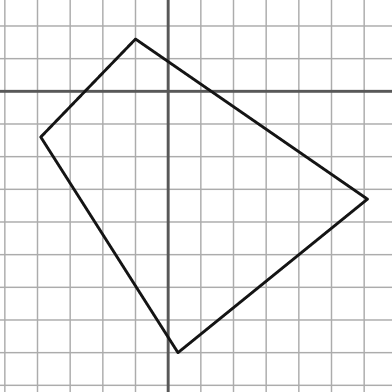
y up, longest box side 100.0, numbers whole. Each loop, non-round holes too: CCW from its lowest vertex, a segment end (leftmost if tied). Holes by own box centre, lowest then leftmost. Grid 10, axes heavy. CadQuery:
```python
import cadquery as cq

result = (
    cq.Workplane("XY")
    .moveTo(3.0, -80.0)
    .lineTo(61.0, -33.0)
    .lineTo(-10.0, 16.0)
    .lineTo(-39.0, -14.0)
    .close()
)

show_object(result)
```